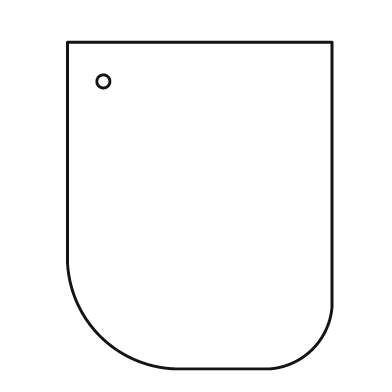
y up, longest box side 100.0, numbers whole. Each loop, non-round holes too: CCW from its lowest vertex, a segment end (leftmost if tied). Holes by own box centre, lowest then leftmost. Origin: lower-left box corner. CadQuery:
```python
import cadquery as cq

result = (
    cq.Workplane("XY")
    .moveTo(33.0, 0.0)
    .lineTo(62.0, 0.0)
    .threePointArc((75.0, 6.0), (81.0, 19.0))
    .lineTo(81.0, 100.0)
    .lineTo(0.0, 100.0)
    .lineTo(0.0, 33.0)
    .threePointArc((10.0, 10.0), (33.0, 0.0))
    .close()
    .moveTo(11.0, 88.0)
    .circle(2.0)
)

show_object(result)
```